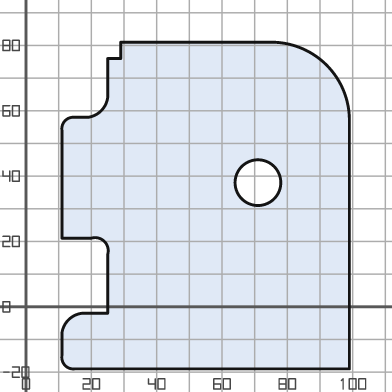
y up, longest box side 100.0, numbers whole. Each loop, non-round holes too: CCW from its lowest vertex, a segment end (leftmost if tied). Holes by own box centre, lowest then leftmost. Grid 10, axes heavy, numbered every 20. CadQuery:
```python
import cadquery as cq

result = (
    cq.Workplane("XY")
    .moveTo(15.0, -19.0)
    .lineTo(99.0, -19.0)
    .lineTo(99.0, 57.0)
    .threePointArc((92.0, 74.0), (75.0, 81.0))
    .lineTo(29.0, 81.0)
    .lineTo(29.0, 76.0)
    .lineTo(25.0, 76.0)
    .lineTo(25.0, 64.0)
    .threePointArc((23.0, 60.0), (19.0, 58.0))
    .lineTo(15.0, 58.0)
    .threePointArc((12.0, 57.0), (11.0, 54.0))
    .lineTo(11.0, 21.0)
    .lineTo(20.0, 21.0)
    .threePointArc((24.0, 20.0), (25.0, 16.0))
    .lineTo(25.0, -2.0)
    .lineTo(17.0, -2.0)
    .threePointArc((13.0, -4.0), (11.0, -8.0))
    .lineTo(11.0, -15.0)
    .threePointArc((12.0, -18.0), (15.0, -19.0))
    .close()
    .moveTo(71.0, 38.0)
    .circle(7.0)
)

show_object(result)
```